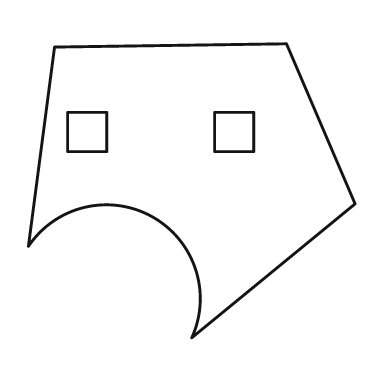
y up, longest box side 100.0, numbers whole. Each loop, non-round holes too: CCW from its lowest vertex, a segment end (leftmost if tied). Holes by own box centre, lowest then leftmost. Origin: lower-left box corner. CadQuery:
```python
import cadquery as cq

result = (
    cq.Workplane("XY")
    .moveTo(50.0, 0.0)
    .lineTo(100.0, 41.0)
    .lineTo(79.0, 90.0)
    .lineTo(8.0, 89.0)
    .lineTo(0.0, 28.0)
    .threePointArc((38.0, 37.0), (50.0, 0.0))
    .close()
    .moveTo(12.0, 57.0)
    .lineTo(24.0, 57.0)
    .lineTo(24.0, 69.0)
    .lineTo(12.0, 69.0)
    .close()
    .moveTo(57.0, 57.0)
    .lineTo(69.0, 57.0)
    .lineTo(69.0, 69.0)
    .lineTo(57.0, 69.0)
    .close()
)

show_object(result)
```